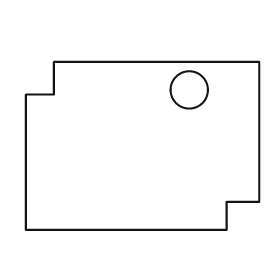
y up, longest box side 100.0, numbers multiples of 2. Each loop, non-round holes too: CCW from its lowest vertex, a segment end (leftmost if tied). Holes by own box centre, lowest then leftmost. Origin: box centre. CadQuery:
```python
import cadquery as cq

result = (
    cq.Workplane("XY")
    .moveTo(-50.0, -36.0)
    .lineTo(36.0, -36.0)
    .lineTo(36.0, -24.0)
    .lineTo(50.0, -24.0)
    .lineTo(50.0, 36.0)
    .lineTo(-38.0, 36.0)
    .lineTo(-38.0, 22.0)
    .lineTo(-50.0, 22.0)
    .close()
    .moveTo(20.0, 24.0)
    .circle(8.0)
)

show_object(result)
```